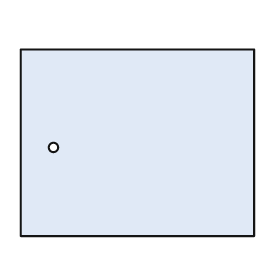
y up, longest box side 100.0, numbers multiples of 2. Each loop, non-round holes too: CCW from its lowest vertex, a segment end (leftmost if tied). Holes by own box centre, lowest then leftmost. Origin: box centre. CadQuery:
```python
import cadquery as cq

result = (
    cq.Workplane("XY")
    .moveTo(-50.0, -40.0)
    .lineTo(50.0, -40.0)
    .lineTo(50.0, 40.0)
    .lineTo(-50.0, 40.0)
    .close()
    .moveTo(-36.0, -2.0)
    .circle(2.0)
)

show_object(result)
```